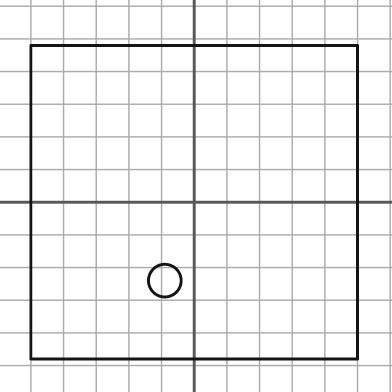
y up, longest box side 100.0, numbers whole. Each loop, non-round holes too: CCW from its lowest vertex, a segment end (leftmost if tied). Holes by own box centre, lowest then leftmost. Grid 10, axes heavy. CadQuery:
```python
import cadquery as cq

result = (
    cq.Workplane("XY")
    .moveTo(-50.0, -48.0)
    .lineTo(50.0, -48.0)
    .lineTo(50.0, 48.0)
    .lineTo(-50.0, 48.0)
    .close()
    .moveTo(-9.0, -24.0)
    .circle(5.0)
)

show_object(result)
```